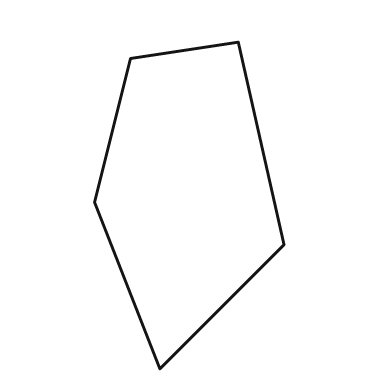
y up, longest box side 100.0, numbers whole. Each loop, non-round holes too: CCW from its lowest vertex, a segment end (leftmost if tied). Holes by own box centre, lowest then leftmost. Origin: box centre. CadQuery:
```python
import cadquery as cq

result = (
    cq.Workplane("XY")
    .moveTo(-9.0, -50.0)
    .lineTo(29.0, -12.0)
    .lineTo(15.0, 50.0)
    .lineTo(-18.0, 45.0)
    .lineTo(-29.0, 1.0)
    .close()
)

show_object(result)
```